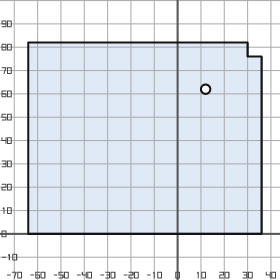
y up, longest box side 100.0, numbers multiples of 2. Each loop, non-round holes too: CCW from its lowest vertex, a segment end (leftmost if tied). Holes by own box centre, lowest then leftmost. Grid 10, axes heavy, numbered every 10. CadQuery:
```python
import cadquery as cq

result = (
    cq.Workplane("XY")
    .moveTo(-64.0, 0.0)
    .lineTo(36.0, 0.0)
    .lineTo(36.0, 76.0)
    .lineTo(30.0, 76.0)
    .lineTo(30.0, 82.0)
    .lineTo(-64.0, 82.0)
    .close()
    .moveTo(12.0, 62.0)
    .circle(2.0)
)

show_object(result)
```